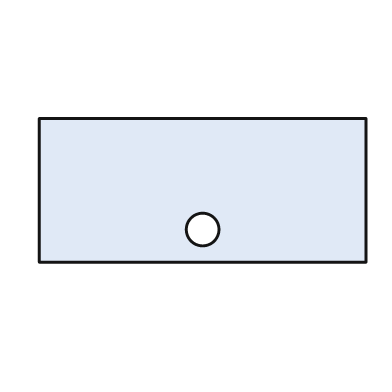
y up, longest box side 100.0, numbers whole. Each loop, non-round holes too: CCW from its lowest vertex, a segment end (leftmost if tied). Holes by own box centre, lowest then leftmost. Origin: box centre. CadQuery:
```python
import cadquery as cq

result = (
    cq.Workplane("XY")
    .moveTo(-50.0, -22.0)
    .lineTo(50.0, -22.0)
    .lineTo(50.0, 22.0)
    .lineTo(-50.0, 22.0)
    .close()
    .moveTo(0.0, -12.0)
    .circle(5.0)
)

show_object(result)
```